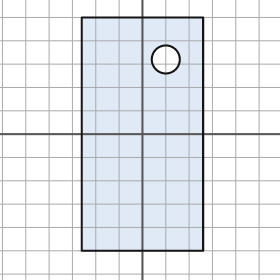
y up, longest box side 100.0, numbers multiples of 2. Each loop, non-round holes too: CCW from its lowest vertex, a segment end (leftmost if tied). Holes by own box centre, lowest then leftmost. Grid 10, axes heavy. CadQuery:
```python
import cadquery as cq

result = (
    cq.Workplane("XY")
    .moveTo(-26.0, -50.0)
    .lineTo(26.0, -50.0)
    .lineTo(26.0, 50.0)
    .lineTo(-26.0, 50.0)
    .close()
    .moveTo(10.0, 32.0)
    .circle(6.0)
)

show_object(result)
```